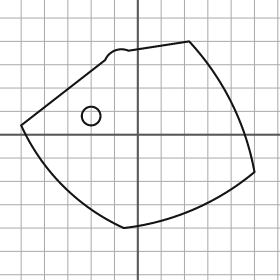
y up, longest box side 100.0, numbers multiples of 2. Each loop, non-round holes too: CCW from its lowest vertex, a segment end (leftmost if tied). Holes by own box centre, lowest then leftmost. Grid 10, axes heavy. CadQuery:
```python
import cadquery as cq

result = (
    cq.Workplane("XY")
    .moveTo(-6.0, -40.0)
    .threePointArc((24.0, -32.0), (50.0, -16.0))
    .threePointArc((40.0, 14.0), (22.0, 40.0))
    .lineTo(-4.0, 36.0)
    .threePointArc((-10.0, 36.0), (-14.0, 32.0))
    .lineTo(-50.0, 4.0)
    .threePointArc((-32.0, -22.0), (-6.0, -40.0))
    .close()
    .moveTo(-20.0, 8.0)
    .circle(4.0)
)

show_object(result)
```